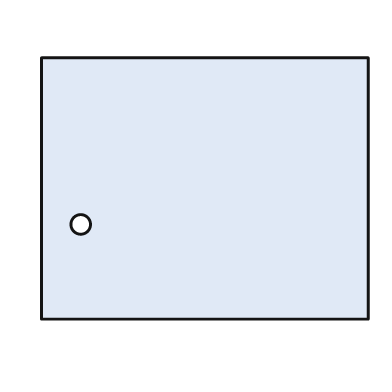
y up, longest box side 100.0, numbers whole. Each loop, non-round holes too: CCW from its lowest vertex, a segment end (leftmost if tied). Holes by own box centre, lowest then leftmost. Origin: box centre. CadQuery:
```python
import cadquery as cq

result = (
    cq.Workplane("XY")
    .moveTo(-50.0, -40.0)
    .lineTo(50.0, -40.0)
    .lineTo(50.0, 40.0)
    .lineTo(-50.0, 40.0)
    .close()
    .moveTo(-38.0, -11.0)
    .circle(3.0)
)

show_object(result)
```